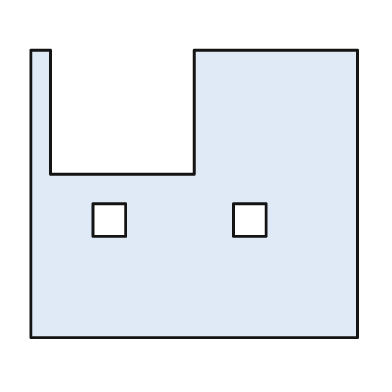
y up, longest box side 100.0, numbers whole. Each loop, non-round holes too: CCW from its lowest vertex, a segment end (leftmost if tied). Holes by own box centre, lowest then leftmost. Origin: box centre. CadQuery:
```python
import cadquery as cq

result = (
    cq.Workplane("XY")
    .moveTo(-50.0, -44.0)
    .lineTo(50.0, -44.0)
    .lineTo(50.0, 44.0)
    .lineTo(0.0, 44.0)
    .lineTo(0.0, 6.0)
    .lineTo(-44.0, 6.0)
    .lineTo(-44.0, 44.0)
    .lineTo(-50.0, 44.0)
    .close()
    .moveTo(-31.0, -13.0)
    .lineTo(-21.0, -13.0)
    .lineTo(-21.0, -3.0)
    .lineTo(-31.0, -3.0)
    .close()
    .moveTo(12.0, -13.0)
    .lineTo(22.0, -13.0)
    .lineTo(22.0, -3.0)
    .lineTo(12.0, -3.0)
    .close()
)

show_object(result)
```